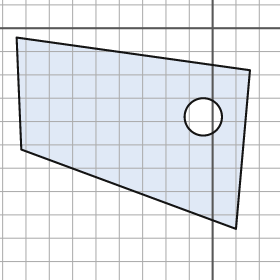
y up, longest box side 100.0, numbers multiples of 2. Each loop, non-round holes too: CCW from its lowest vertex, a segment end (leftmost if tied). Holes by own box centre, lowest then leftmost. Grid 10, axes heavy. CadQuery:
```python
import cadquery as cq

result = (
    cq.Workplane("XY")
    .moveTo(10.0, -86.0)
    .lineTo(16.0, -18.0)
    .lineTo(-84.0, -4.0)
    .lineTo(-82.0, -52.0)
    .close()
    .moveTo(-4.0, -38.0)
    .circle(8.0)
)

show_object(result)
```